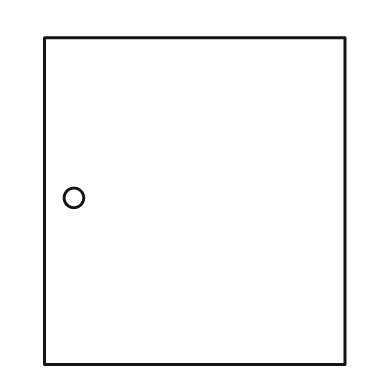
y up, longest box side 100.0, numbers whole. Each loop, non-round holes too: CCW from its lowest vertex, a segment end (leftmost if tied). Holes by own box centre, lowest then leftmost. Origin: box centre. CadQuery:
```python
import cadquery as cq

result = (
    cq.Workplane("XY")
    .moveTo(-46.0, -50.0)
    .lineTo(46.0, -50.0)
    .lineTo(46.0, 50.0)
    .lineTo(-46.0, 50.0)
    .close()
    .moveTo(-37.0, 1.0)
    .circle(3.0)
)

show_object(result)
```